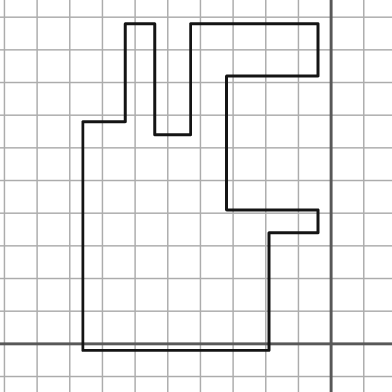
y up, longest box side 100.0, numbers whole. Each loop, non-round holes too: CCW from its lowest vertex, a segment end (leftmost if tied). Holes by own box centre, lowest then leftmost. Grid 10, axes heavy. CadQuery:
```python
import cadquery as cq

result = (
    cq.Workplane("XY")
    .moveTo(-76.0, -2.0)
    .lineTo(-19.0, -2.0)
    .lineTo(-19.0, 34.0)
    .lineTo(-4.0, 34.0)
    .lineTo(-4.0, 41.0)
    .lineTo(-32.0, 41.0)
    .lineTo(-32.0, 82.0)
    .lineTo(-4.0, 82.0)
    .lineTo(-4.0, 98.0)
    .lineTo(-43.0, 98.0)
    .lineTo(-43.0, 64.0)
    .lineTo(-54.0, 64.0)
    .lineTo(-54.0, 98.0)
    .lineTo(-63.0, 98.0)
    .lineTo(-63.0, 68.0)
    .lineTo(-76.0, 68.0)
    .close()
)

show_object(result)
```